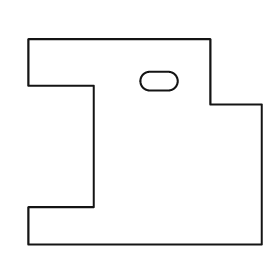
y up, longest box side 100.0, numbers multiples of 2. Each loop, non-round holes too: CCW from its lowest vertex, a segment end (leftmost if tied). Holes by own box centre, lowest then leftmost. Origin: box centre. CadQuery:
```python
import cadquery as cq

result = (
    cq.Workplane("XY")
    .moveTo(-50.0, -44.0)
    .lineTo(50.0, -44.0)
    .lineTo(50.0, 16.0)
    .lineTo(28.0, 16.0)
    .lineTo(28.0, 44.0)
    .lineTo(-50.0, 44.0)
    .lineTo(-50.0, 24.0)
    .lineTo(-22.0, 24.0)
    .lineTo(-22.0, -28.0)
    .lineTo(-50.0, -28.0)
    .close()
    .moveTo(2.0, 22.0)
    .lineTo(10.0, 22.0)
    .threePointArc((14.0, 26.0), (10.0, 30.0))
    .lineTo(2.0, 30.0)
    .threePointArc((-2.0, 26.0), (2.0, 22.0))
    .close()
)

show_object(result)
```